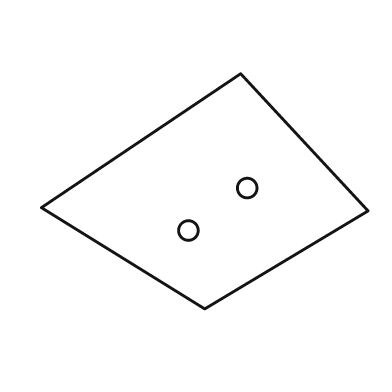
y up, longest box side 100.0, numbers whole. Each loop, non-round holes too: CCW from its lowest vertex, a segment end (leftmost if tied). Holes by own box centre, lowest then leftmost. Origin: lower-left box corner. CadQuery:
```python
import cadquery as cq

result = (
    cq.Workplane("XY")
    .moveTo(50.0, 0.0)
    .lineTo(100.0, 30.0)
    .lineTo(61.0, 72.0)
    .lineTo(0.0, 31.0)
    .close()
    .moveTo(45.0, 24.0)
    .circle(3.0)
    .moveTo(63.0, 37.0)
    .circle(3.0)
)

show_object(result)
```